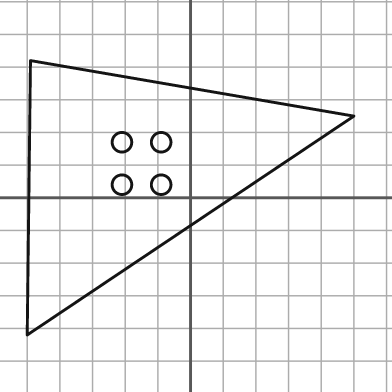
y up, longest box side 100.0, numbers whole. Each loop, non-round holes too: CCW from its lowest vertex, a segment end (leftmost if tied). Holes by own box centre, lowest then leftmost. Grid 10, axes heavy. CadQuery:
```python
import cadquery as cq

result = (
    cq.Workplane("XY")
    .moveTo(-50.0, -42.0)
    .lineTo(50.0, 25.0)
    .lineTo(-49.0, 42.0)
    .close()
    .moveTo(-21.0, 4.0)
    .circle(3.0)
    .moveTo(-9.0, 4.0)
    .circle(3.0)
    .moveTo(-21.0, 17.0)
    .circle(3.0)
    .moveTo(-9.0, 17.0)
    .circle(3.0)
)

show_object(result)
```